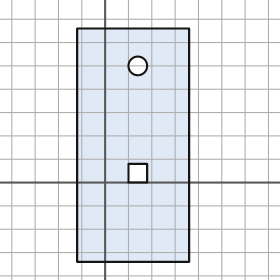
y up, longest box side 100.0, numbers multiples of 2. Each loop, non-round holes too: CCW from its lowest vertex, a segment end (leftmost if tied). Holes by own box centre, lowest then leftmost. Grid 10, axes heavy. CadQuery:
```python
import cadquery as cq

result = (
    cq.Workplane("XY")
    .moveTo(-12.0, -34.0)
    .lineTo(36.0, -34.0)
    .lineTo(36.0, 66.0)
    .lineTo(-12.0, 66.0)
    .close()
    .moveTo(10.0, 0.0)
    .lineTo(18.0, 0.0)
    .lineTo(18.0, 8.0)
    .lineTo(10.0, 8.0)
    .close()
    .moveTo(14.0, 50.0)
    .circle(4.0)
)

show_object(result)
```